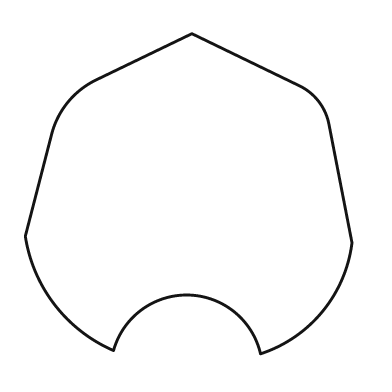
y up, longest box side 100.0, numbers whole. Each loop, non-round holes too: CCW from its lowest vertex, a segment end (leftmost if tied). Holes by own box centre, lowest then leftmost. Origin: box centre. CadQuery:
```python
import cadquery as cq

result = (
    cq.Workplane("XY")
    .moveTo(22.0, -49.0)
    .threePointArc((41.0, -36.0), (50.0, -15.0))
    .lineTo(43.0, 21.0)
    .threePointArc((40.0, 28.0), (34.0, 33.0))
    .lineTo(1.0, 49.0)
    .lineTo(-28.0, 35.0)
    .threePointArc((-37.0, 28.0), (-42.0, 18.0))
    .lineTo(-50.0, -13.0)
    .threePointArc((-41.0, -34.0), (-23.0, -48.0))
    .threePointArc((0.0, -31.0), (22.0, -49.0))
    .close()
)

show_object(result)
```